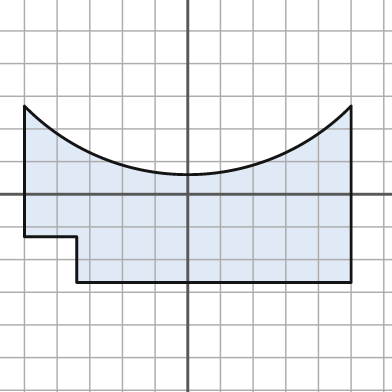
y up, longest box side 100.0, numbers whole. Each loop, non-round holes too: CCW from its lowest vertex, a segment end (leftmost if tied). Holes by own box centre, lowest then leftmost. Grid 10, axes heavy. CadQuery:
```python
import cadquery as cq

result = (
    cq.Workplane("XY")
    .moveTo(-34.0, -27.0)
    .lineTo(50.0, -27.0)
    .lineTo(50.0, 27.0)
    .threePointArc((0.0, 6.0), (-50.0, 27.0))
    .lineTo(-50.0, -13.0)
    .lineTo(-34.0, -13.0)
    .close()
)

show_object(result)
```